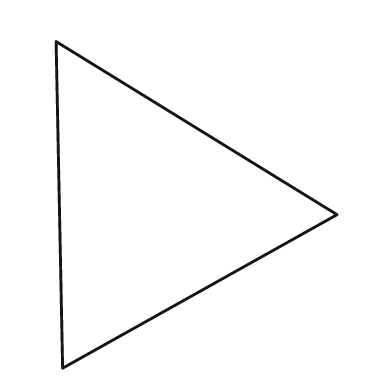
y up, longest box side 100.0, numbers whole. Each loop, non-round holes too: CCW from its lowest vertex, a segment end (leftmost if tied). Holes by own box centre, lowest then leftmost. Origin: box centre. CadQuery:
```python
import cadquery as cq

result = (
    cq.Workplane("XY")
    .moveTo(-41.0, -50.0)
    .lineTo(43.0, -3.0)
    .lineTo(-43.0, 50.0)
    .close()
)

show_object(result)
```